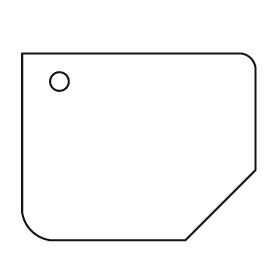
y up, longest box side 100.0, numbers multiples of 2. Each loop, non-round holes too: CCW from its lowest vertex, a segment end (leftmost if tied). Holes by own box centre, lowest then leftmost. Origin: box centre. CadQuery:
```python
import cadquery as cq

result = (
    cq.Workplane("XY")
    .moveTo(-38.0, -40.0)
    .lineTo(20.0, -40.0)
    .lineTo(50.0, -10.0)
    .lineTo(50.0, 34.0)
    .threePointArc((48.0, 38.0), (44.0, 40.0))
    .lineTo(-50.0, 40.0)
    .lineTo(-50.0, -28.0)
    .threePointArc((-46.0, -36.0), (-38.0, -40.0))
    .close()
    .moveTo(-34.0, 28.0)
    .circle(4.0)
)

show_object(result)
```